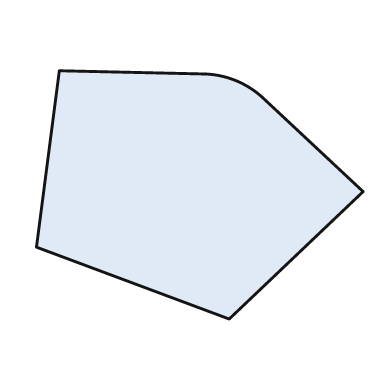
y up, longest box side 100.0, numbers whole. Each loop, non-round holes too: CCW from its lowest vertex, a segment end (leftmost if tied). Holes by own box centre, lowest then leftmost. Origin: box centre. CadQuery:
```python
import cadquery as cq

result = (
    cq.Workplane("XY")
    .moveTo(9.0, -38.0)
    .lineTo(50.0, 1.0)
    .lineTo(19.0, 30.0)
    .threePointArc((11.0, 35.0), (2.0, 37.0))
    .lineTo(-43.0, 38.0)
    .lineTo(-50.0, -16.0)
    .close()
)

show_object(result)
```